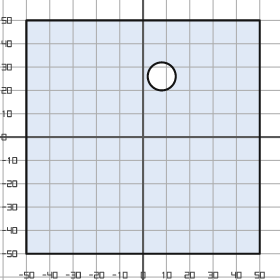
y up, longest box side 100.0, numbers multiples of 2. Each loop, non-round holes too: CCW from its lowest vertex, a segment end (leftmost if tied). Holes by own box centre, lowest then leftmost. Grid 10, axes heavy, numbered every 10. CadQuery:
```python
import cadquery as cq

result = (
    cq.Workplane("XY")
    .moveTo(-50.0, -50.0)
    .lineTo(50.0, -50.0)
    .lineTo(50.0, 50.0)
    .lineTo(-50.0, 50.0)
    .close()
    .moveTo(8.0, 26.0)
    .circle(6.0)
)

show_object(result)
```